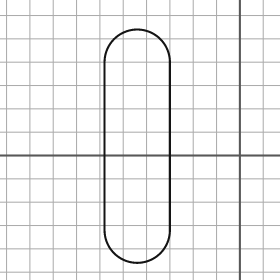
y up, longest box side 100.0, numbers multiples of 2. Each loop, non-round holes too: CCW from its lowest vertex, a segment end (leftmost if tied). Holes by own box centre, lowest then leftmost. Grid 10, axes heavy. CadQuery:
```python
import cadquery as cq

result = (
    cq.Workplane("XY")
    .moveTo(-58.0, -32.0)
    .threePointArc((-44.0, -46.0), (-30.0, -32.0))
    .lineTo(-30.0, 40.0)
    .threePointArc((-44.0, 54.0), (-58.0, 40.0))
    .close()
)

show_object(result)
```